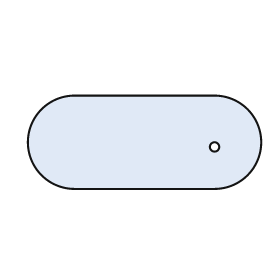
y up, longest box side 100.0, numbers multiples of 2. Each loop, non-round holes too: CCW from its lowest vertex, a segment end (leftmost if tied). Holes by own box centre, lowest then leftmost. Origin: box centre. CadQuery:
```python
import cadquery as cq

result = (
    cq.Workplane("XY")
    .moveTo(-30.0, -20.0)
    .lineTo(30.0, -20.0)
    .threePointArc((50.0, 0.0), (30.0, 20.0))
    .lineTo(-30.0, 20.0)
    .threePointArc((-50.0, 0.0), (-30.0, -20.0))
    .close()
    .moveTo(30.0, -2.0)
    .circle(2.0)
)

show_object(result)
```